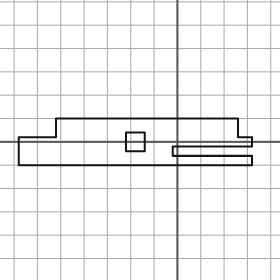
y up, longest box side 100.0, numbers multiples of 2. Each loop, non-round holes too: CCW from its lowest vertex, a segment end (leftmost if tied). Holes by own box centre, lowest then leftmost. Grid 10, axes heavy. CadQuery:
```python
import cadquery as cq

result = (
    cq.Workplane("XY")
    .moveTo(-68.0, -10.0)
    .lineTo(32.0, -10.0)
    .lineTo(32.0, -6.0)
    .lineTo(-2.0, -6.0)
    .lineTo(-2.0, -2.0)
    .lineTo(32.0, -2.0)
    .lineTo(32.0, 2.0)
    .lineTo(26.0, 2.0)
    .lineTo(26.0, 10.0)
    .lineTo(-52.0, 10.0)
    .lineTo(-52.0, 2.0)
    .lineTo(-68.0, 2.0)
    .close()
    .moveTo(-22.0, -4.0)
    .lineTo(-14.0, -4.0)
    .lineTo(-14.0, 4.0)
    .lineTo(-22.0, 4.0)
    .close()
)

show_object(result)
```